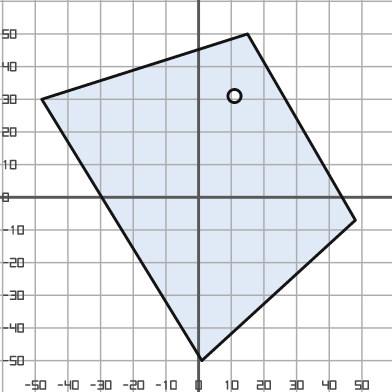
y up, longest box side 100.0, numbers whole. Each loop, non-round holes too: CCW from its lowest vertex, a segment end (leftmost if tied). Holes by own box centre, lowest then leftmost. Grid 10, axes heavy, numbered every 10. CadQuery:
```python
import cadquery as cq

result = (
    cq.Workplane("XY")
    .moveTo(1.0, -50.0)
    .lineTo(48.0, -7.0)
    .lineTo(15.0, 50.0)
    .lineTo(-48.0, 30.0)
    .close()
    .moveTo(11.0, 31.0)
    .circle(2.0)
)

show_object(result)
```